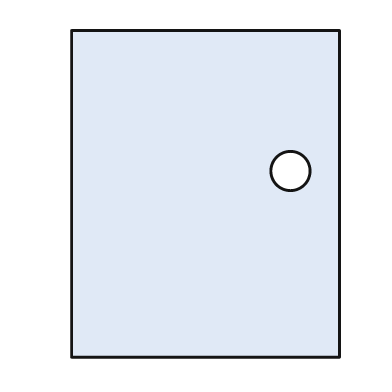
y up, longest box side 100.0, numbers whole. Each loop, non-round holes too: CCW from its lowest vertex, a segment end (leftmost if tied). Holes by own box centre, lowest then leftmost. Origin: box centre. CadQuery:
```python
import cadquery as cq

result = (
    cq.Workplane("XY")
    .moveTo(-41.0, -50.0)
    .lineTo(41.0, -50.0)
    .lineTo(41.0, 50.0)
    .lineTo(-41.0, 50.0)
    .close()
    .moveTo(26.0, 7.0)
    .circle(6.0)
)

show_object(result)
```